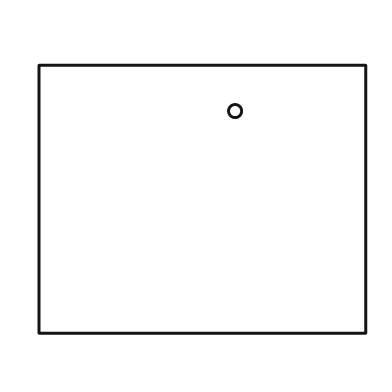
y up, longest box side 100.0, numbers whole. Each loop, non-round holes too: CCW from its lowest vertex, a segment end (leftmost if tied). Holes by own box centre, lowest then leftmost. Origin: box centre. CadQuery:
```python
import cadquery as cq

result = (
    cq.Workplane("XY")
    .moveTo(-50.0, -41.0)
    .lineTo(50.0, -41.0)
    .lineTo(50.0, 41.0)
    .lineTo(-50.0, 41.0)
    .close()
    .moveTo(10.0, 27.0)
    .circle(2.0)
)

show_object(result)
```